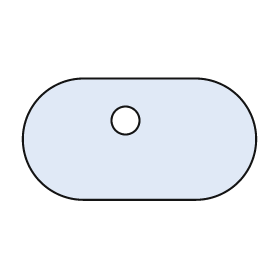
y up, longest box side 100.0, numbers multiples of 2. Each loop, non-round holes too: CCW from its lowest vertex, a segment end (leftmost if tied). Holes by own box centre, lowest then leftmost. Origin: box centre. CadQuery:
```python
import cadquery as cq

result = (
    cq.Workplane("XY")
    .moveTo(-24.0, -26.0)
    .lineTo(24.0, -26.0)
    .threePointArc((50.0, 0.0), (24.0, 26.0))
    .lineTo(-24.0, 26.0)
    .threePointArc((-50.0, 0.0), (-24.0, -26.0))
    .close()
    .moveTo(-6.0, 8.0)
    .circle(6.0)
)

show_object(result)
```